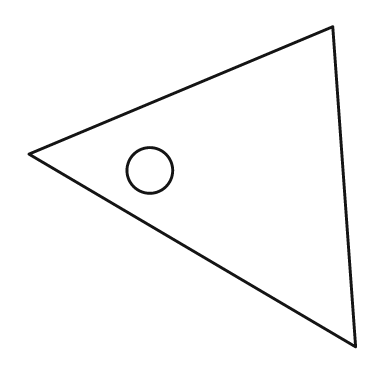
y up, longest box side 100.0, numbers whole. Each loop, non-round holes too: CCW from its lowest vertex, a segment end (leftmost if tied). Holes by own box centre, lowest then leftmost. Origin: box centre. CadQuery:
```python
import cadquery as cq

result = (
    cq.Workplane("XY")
    .moveTo(50.0, -49.0)
    .lineTo(43.0, 49.0)
    .lineTo(-50.0, 10.0)
    .close()
    .moveTo(-13.0, 5.0)
    .circle(7.0)
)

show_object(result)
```